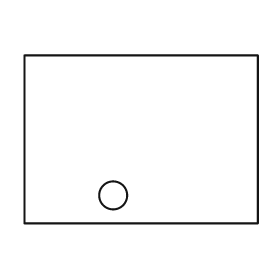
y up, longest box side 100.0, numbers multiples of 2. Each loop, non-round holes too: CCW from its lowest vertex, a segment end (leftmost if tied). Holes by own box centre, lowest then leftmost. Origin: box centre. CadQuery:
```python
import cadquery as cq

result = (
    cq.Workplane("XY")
    .moveTo(-50.0, -36.0)
    .lineTo(50.0, -36.0)
    .lineTo(50.0, 36.0)
    .lineTo(-50.0, 36.0)
    .close()
    .moveTo(-12.0, -24.0)
    .circle(6.0)
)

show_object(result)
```